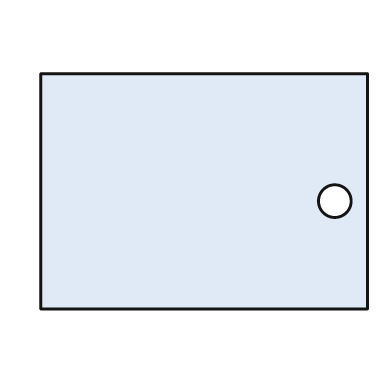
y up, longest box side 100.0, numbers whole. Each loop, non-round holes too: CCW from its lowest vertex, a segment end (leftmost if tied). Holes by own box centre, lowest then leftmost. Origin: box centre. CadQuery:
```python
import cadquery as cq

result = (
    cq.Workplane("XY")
    .moveTo(-50.0, -36.0)
    .lineTo(50.0, -36.0)
    .lineTo(50.0, 36.0)
    .lineTo(-50.0, 36.0)
    .close()
    .moveTo(40.0, -3.0)
    .circle(5.0)
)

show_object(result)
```